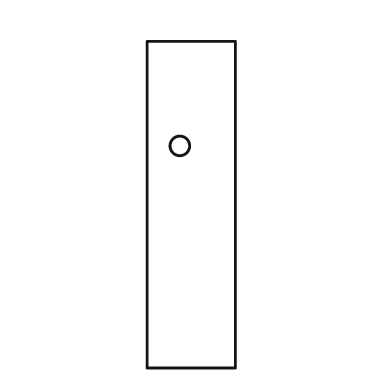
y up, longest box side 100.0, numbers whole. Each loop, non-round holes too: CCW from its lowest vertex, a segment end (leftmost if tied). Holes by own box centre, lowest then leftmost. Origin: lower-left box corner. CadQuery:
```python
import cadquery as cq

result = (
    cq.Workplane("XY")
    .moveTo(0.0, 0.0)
    .lineTo(27.0, 0.0)
    .lineTo(27.0, 100.0)
    .lineTo(0.0, 100.0)
    .close()
    .moveTo(10.0, 68.0)
    .circle(3.0)
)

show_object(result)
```